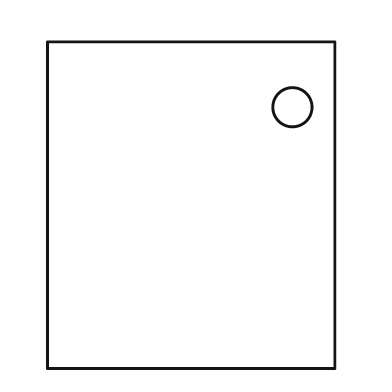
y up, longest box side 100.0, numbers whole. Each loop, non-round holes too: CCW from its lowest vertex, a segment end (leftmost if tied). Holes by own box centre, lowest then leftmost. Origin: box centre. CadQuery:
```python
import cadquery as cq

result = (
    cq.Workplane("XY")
    .moveTo(-44.0, -50.0)
    .lineTo(44.0, -50.0)
    .lineTo(44.0, 50.0)
    .lineTo(-44.0, 50.0)
    .close()
    .moveTo(31.0, 30.0)
    .circle(6.0)
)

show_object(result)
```